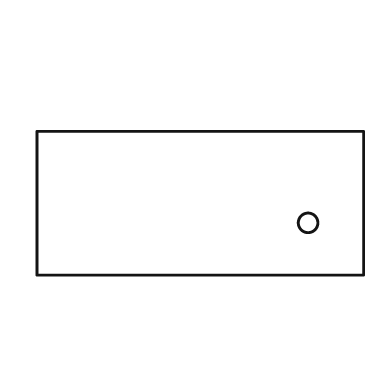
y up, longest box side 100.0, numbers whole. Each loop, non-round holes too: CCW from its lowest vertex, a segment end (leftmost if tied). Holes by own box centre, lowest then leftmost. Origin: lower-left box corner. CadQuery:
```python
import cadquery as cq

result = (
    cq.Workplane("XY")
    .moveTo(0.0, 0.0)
    .lineTo(100.0, 0.0)
    .lineTo(100.0, 44.0)
    .lineTo(0.0, 44.0)
    .close()
    .moveTo(83.0, 16.0)
    .circle(3.0)
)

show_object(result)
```